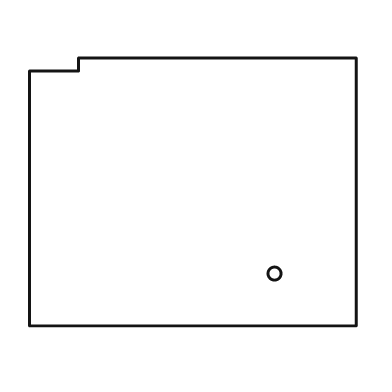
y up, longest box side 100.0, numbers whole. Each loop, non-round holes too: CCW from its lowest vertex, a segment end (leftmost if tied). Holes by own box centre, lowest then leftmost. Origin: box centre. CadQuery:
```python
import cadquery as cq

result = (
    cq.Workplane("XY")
    .moveTo(-50.0, -41.0)
    .lineTo(50.0, -41.0)
    .lineTo(50.0, 41.0)
    .lineTo(-35.0, 41.0)
    .lineTo(-35.0, 37.0)
    .lineTo(-50.0, 37.0)
    .close()
    .moveTo(25.0, -25.0)
    .circle(2.0)
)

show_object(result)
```